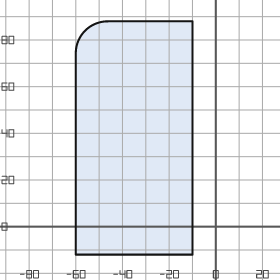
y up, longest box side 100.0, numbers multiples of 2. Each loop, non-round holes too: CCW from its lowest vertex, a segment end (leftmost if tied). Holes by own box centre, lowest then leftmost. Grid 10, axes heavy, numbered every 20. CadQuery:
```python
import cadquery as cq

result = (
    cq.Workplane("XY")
    .moveTo(-60.0, -12.0)
    .lineTo(-10.0, -12.0)
    .lineTo(-10.0, 88.0)
    .lineTo(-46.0, 88.0)
    .threePointArc((-56.0, 84.0), (-60.0, 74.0))
    .close()
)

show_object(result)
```